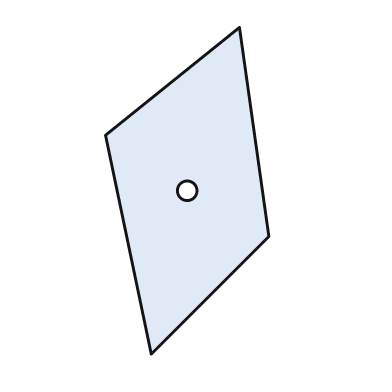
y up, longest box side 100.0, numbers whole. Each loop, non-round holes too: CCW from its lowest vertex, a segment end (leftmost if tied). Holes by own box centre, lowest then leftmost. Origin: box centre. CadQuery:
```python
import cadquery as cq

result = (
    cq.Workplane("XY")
    .moveTo(-11.0, -50.0)
    .lineTo(25.0, -14.0)
    .lineTo(16.0, 50.0)
    .lineTo(-25.0, 17.0)
    .close()
    .moveTo(0.0, 0.0)
    .circle(3.0)
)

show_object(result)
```